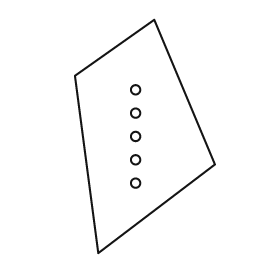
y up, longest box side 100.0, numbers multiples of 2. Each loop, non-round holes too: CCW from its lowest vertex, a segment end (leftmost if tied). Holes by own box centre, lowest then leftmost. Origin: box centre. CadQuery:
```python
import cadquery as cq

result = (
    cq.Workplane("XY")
    .moveTo(-20.0, -50.0)
    .lineTo(30.0, -12.0)
    .lineTo(4.0, 50.0)
    .lineTo(-30.0, 26.0)
    .close()
    .moveTo(-4.0, -20.0)
    .circle(2.0)
    .moveTo(-4.0, -10.0)
    .circle(2.0)
    .moveTo(-4.0, 0.0)
    .circle(2.0)
    .moveTo(-4.0, 10.0)
    .circle(2.0)
    .moveTo(-4.0, 20.0)
    .circle(2.0)
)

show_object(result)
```